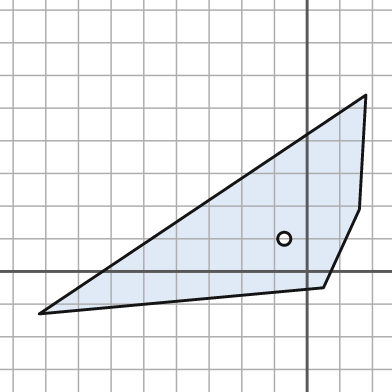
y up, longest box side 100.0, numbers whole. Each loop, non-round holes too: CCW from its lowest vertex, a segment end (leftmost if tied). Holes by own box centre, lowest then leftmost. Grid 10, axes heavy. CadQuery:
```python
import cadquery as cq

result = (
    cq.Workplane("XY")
    .moveTo(-82.0, -13.0)
    .lineTo(5.0, -5.0)
    .lineTo(16.0, 19.0)
    .lineTo(18.0, 54.0)
    .close()
    .moveTo(-7.0, 10.0)
    .circle(2.0)
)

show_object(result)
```